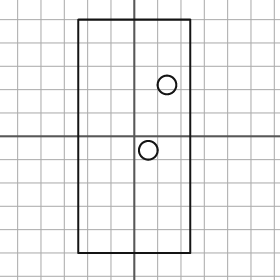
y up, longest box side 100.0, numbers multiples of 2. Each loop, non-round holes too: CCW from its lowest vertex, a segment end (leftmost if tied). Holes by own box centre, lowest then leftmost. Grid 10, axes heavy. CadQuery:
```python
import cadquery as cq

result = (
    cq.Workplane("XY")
    .moveTo(-24.0, -50.0)
    .lineTo(24.0, -50.0)
    .lineTo(24.0, 50.0)
    .lineTo(-24.0, 50.0)
    .close()
    .moveTo(6.0, -6.0)
    .circle(4.0)
    .moveTo(14.0, 22.0)
    .circle(4.0)
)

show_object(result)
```